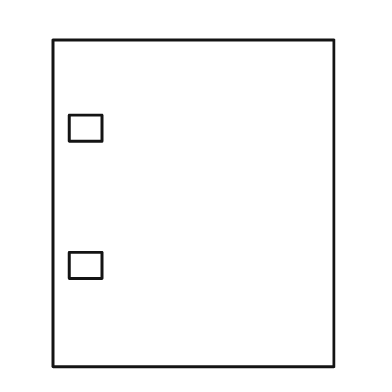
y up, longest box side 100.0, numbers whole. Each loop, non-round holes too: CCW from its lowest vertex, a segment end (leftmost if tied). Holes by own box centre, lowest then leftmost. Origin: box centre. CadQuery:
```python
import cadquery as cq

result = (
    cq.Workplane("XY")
    .moveTo(-43.0, -50.0)
    .lineTo(43.0, -50.0)
    .lineTo(43.0, 50.0)
    .lineTo(-43.0, 50.0)
    .close()
    .moveTo(-38.0, -23.0)
    .lineTo(-28.0, -23.0)
    .lineTo(-28.0, -15.0)
    .lineTo(-38.0, -15.0)
    .close()
    .moveTo(-38.0, 19.0)
    .lineTo(-28.0, 19.0)
    .lineTo(-28.0, 27.0)
    .lineTo(-38.0, 27.0)
    .close()
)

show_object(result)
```